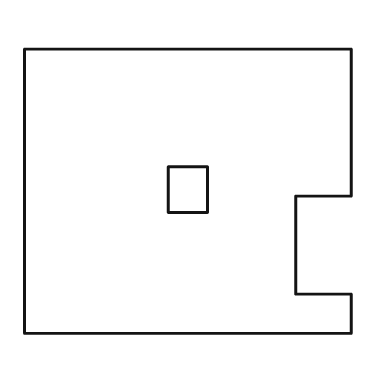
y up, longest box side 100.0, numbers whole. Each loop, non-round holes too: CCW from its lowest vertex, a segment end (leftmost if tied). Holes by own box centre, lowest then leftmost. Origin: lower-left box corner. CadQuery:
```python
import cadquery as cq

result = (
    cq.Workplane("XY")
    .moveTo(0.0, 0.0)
    .lineTo(100.0, 0.0)
    .lineTo(100.0, 12.0)
    .lineTo(83.0, 12.0)
    .lineTo(83.0, 42.0)
    .lineTo(100.0, 42.0)
    .lineTo(100.0, 87.0)
    .lineTo(0.0, 87.0)
    .close()
    .moveTo(44.0, 37.0)
    .lineTo(56.0, 37.0)
    .lineTo(56.0, 51.0)
    .lineTo(44.0, 51.0)
    .close()
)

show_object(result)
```